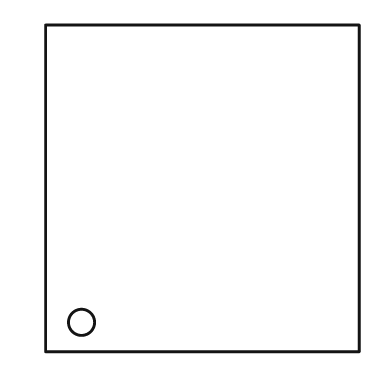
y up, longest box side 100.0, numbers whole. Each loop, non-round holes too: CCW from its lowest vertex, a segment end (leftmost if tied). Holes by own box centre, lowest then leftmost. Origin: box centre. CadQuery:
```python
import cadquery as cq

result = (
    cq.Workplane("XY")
    .moveTo(-48.0, -50.0)
    .lineTo(48.0, -50.0)
    .lineTo(48.0, 50.0)
    .lineTo(-48.0, 50.0)
    .close()
    .moveTo(-37.0, -41.0)
    .circle(4.0)
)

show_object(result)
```